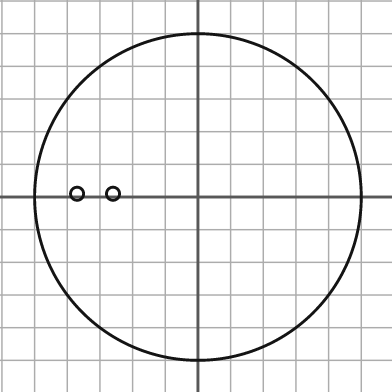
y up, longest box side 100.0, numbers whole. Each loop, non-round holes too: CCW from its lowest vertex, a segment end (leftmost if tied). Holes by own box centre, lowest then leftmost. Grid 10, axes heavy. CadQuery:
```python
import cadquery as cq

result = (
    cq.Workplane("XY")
    .moveTo(0.0, 0.0)
    .circle(50.0)
    .moveTo(-37.0, 1.0)
    .circle(2.0)
    .moveTo(-26.0, 1.0)
    .circle(2.0)
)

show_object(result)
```